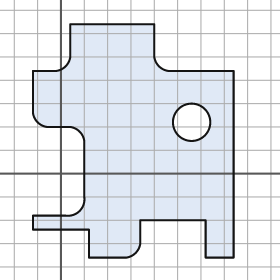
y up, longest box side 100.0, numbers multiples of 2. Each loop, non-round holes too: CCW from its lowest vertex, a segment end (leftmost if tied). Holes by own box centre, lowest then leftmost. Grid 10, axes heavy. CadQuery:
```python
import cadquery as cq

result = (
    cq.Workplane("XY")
    .moveTo(12.0, -36.0)
    .lineTo(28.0, -36.0)
    .threePointArc((32.0, -34.0), (34.0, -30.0))
    .lineTo(34.0, -20.0)
    .lineTo(62.0, -20.0)
    .lineTo(62.0, -36.0)
    .lineTo(74.0, -36.0)
    .lineTo(74.0, 44.0)
    .lineTo(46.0, 44.0)
    .threePointArc((42.0, 46.0), (40.0, 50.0))
    .lineTo(40.0, 64.0)
    .lineTo(4.0, 64.0)
    .lineTo(4.0, 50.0)
    .threePointArc((2.0, 46.0), (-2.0, 44.0))
    .lineTo(-12.0, 44.0)
    .lineTo(-12.0, 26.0)
    .threePointArc((-10.0, 22.0), (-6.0, 20.0))
    .lineTo(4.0, 20.0)
    .threePointArc((8.0, 18.0), (10.0, 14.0))
    .lineTo(10.0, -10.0)
    .threePointArc((8.0, -16.0), (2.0, -18.0))
    .lineTo(-12.0, -18.0)
    .lineTo(-12.0, -24.0)
    .lineTo(12.0, -24.0)
    .close()
    .moveTo(56.0, 22.0)
    .circle(8.0)
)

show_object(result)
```